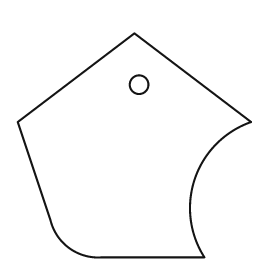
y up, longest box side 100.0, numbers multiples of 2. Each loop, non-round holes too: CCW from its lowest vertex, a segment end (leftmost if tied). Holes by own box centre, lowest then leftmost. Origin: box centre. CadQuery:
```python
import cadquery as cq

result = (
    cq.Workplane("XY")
    .moveTo(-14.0, -48.0)
    .lineTo(30.0, -48.0)
    .threePointArc((26.0, -14.0), (50.0, 10.0))
    .lineTo(0.0, 48.0)
    .lineTo(-50.0, 10.0)
    .lineTo(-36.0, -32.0)
    .threePointArc((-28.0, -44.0), (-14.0, -48.0))
    .close()
    .moveTo(2.0, 26.0)
    .circle(4.0)
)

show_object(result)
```